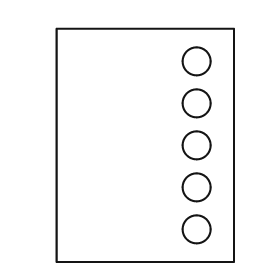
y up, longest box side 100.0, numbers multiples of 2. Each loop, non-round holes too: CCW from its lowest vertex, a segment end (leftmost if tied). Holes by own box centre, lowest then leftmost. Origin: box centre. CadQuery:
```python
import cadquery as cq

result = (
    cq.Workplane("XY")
    .moveTo(-38.0, -50.0)
    .lineTo(38.0, -50.0)
    .lineTo(38.0, 50.0)
    .lineTo(-38.0, 50.0)
    .close()
    .moveTo(22.0, -36.0)
    .circle(6.0)
    .moveTo(22.0, -18.0)
    .circle(6.0)
    .moveTo(22.0, 0.0)
    .circle(6.0)
    .moveTo(22.0, 18.0)
    .circle(6.0)
    .moveTo(22.0, 36.0)
    .circle(6.0)
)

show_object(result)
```